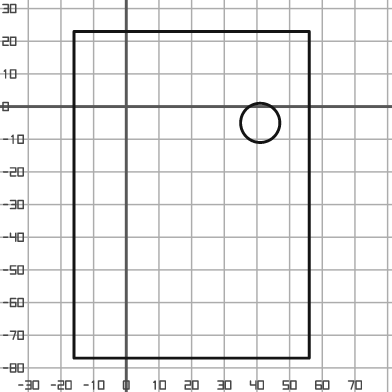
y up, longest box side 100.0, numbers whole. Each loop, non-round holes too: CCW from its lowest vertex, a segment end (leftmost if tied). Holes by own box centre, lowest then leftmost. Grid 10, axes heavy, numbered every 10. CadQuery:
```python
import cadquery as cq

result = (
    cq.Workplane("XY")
    .moveTo(-16.0, -77.0)
    .lineTo(56.0, -77.0)
    .lineTo(56.0, 23.0)
    .lineTo(-16.0, 23.0)
    .close()
    .moveTo(41.0, -5.0)
    .circle(6.0)
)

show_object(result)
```